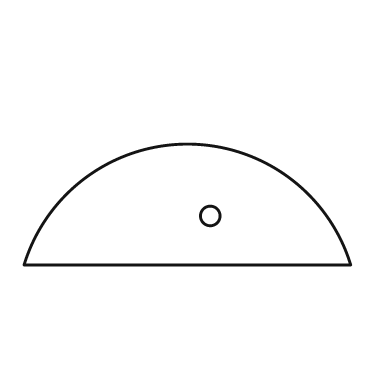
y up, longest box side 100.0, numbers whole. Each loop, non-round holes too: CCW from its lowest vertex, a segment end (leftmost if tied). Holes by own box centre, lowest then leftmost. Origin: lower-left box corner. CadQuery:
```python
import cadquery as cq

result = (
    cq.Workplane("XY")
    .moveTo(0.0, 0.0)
    .lineTo(100.0, 0.0)
    .threePointArc((50.0, 37.0), (0.0, 0.0))
    .close()
    .moveTo(57.0, 15.0)
    .circle(3.0)
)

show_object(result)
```